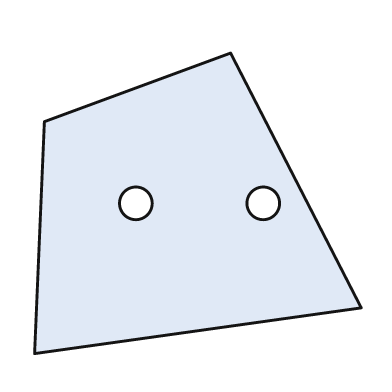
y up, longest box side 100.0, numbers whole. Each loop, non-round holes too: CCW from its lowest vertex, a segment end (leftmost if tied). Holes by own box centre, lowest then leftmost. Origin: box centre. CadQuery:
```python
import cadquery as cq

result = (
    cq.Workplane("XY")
    .moveTo(-50.0, -46.0)
    .lineTo(50.0, -32.0)
    .lineTo(10.0, 46.0)
    .lineTo(-47.0, 25.0)
    .close()
    .moveTo(-19.0, 0.0)
    .circle(5.0)
    .moveTo(20.0, 0.0)
    .circle(5.0)
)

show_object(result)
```